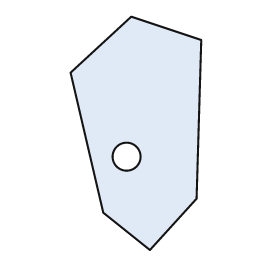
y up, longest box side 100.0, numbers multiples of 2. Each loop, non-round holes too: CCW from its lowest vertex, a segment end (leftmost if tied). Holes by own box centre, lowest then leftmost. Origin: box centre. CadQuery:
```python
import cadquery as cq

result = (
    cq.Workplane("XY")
    .moveTo(6.0, -50.0)
    .lineTo(26.0, -28.0)
    .lineTo(28.0, 40.0)
    .lineTo(-2.0, 50.0)
    .lineTo(-28.0, 26.0)
    .lineTo(-14.0, -34.0)
    .close()
    .moveTo(-4.0, -10.0)
    .circle(6.0)
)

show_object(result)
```